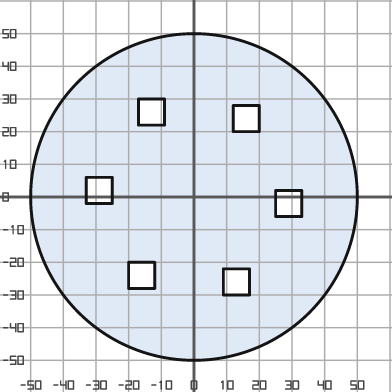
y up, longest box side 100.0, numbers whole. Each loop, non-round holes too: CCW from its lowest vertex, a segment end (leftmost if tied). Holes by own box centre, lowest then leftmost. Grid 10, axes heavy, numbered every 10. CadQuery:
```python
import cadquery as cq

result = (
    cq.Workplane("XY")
    .moveTo(0.0, 0.0)
    .circle(50.0)
    .moveTo(9.0, -30.0)
    .lineTo(17.0, -30.0)
    .lineTo(17.0, -22.0)
    .lineTo(9.0, -22.0)
    .close()
    .moveTo(-20.0, -28.0)
    .lineTo(-12.0, -28.0)
    .lineTo(-12.0, -20.0)
    .lineTo(-20.0, -20.0)
    .close()
    .moveTo(25.0, -6.0)
    .lineTo(33.0, -6.0)
    .lineTo(33.0, 2.0)
    .lineTo(25.0, 2.0)
    .close()
    .moveTo(-33.0, -2.0)
    .lineTo(-25.0, -2.0)
    .lineTo(-25.0, 6.0)
    .lineTo(-33.0, 6.0)
    .close()
    .moveTo(12.0, 20.0)
    .lineTo(20.0, 20.0)
    .lineTo(20.0, 28.0)
    .lineTo(12.0, 28.0)
    .close()
    .moveTo(-17.0, 22.0)
    .lineTo(-9.0, 22.0)
    .lineTo(-9.0, 30.0)
    .lineTo(-17.0, 30.0)
    .close()
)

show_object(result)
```